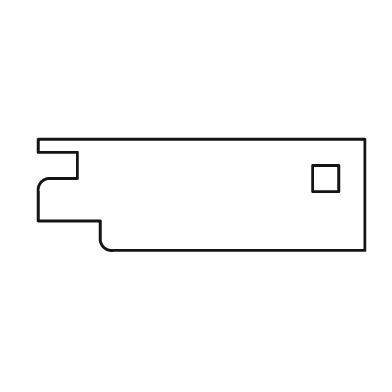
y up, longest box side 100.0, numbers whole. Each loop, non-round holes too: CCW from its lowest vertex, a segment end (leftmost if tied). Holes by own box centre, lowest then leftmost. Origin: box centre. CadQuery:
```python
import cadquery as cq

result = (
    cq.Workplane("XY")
    .moveTo(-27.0, -17.0)
    .lineTo(50.0, -17.0)
    .lineTo(50.0, 17.0)
    .lineTo(-50.0, 17.0)
    .lineTo(-50.0, 13.0)
    .lineTo(-38.0, 13.0)
    .lineTo(-38.0, 5.0)
    .lineTo(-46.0, 5.0)
    .threePointArc((-49.0, 4.0), (-50.0, 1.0))
    .lineTo(-50.0, -8.0)
    .lineTo(-31.0, -8.0)
    .lineTo(-31.0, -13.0)
    .threePointArc((-30.0, -16.0), (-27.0, -17.0))
    .close()
    .moveTo(34.0, 1.0)
    .lineTo(42.0, 1.0)
    .lineTo(42.0, 9.0)
    .lineTo(34.0, 9.0)
    .close()
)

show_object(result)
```